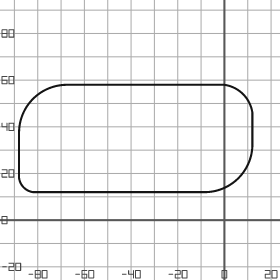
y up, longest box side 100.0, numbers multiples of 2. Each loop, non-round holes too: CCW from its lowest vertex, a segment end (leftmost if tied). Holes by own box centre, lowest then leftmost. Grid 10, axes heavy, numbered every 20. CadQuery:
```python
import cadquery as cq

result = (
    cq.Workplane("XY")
    .moveTo(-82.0, 12.0)
    .lineTo(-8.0, 12.0)
    .threePointArc((6.0, 18.0), (12.0, 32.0))
    .lineTo(12.0, 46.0)
    .threePointArc((8.0, 54.0), (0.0, 58.0))
    .lineTo(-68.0, 58.0)
    .threePointArc((-82.0, 52.0), (-88.0, 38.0))
    .lineTo(-88.0, 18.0)
    .threePointArc((-86.0, 14.0), (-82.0, 12.0))
    .close()
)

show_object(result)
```